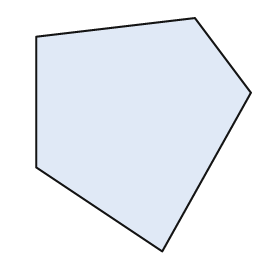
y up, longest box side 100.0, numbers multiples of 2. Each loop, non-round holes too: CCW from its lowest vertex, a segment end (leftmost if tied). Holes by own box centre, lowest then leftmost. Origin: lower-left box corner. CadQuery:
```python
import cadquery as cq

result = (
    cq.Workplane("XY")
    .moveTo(54.0, 0.0)
    .lineTo(92.0, 68.0)
    .lineTo(68.0, 100.0)
    .lineTo(0.0, 92.0)
    .lineTo(0.0, 36.0)
    .close()
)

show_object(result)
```